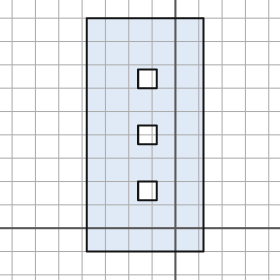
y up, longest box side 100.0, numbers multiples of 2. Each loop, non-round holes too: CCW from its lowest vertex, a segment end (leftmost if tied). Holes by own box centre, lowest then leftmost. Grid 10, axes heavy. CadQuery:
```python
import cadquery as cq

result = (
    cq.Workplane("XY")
    .moveTo(-38.0, -10.0)
    .lineTo(12.0, -10.0)
    .lineTo(12.0, 90.0)
    .lineTo(-38.0, 90.0)
    .close()
    .moveTo(-16.0, 12.0)
    .lineTo(-8.0, 12.0)
    .lineTo(-8.0, 20.0)
    .lineTo(-16.0, 20.0)
    .close()
    .moveTo(-16.0, 36.0)
    .lineTo(-8.0, 36.0)
    .lineTo(-8.0, 44.0)
    .lineTo(-16.0, 44.0)
    .close()
    .moveTo(-16.0, 60.0)
    .lineTo(-8.0, 60.0)
    .lineTo(-8.0, 68.0)
    .lineTo(-16.0, 68.0)
    .close()
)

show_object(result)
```